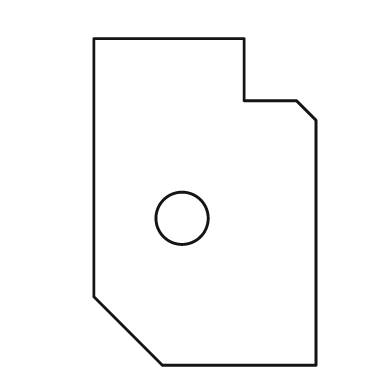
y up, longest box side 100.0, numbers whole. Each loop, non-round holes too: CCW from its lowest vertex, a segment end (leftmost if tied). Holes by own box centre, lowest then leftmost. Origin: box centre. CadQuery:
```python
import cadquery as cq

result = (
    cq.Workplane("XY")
    .moveTo(-13.0, -50.0)
    .lineTo(34.0, -50.0)
    .lineTo(34.0, 25.0)
    .lineTo(28.0, 31.0)
    .lineTo(12.0, 31.0)
    .lineTo(12.0, 50.0)
    .lineTo(-34.0, 50.0)
    .lineTo(-34.0, -29.0)
    .close()
    .moveTo(-7.0, -5.0)
    .circle(8.0)
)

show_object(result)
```